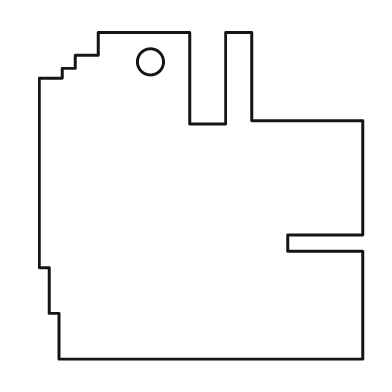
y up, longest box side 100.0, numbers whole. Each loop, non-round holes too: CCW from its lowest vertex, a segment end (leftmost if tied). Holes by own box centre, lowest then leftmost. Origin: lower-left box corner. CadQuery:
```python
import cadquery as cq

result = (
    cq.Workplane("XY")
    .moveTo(6.0, 0.0)
    .lineTo(99.0, 0.0)
    .lineTo(99.0, 33.0)
    .lineTo(76.0, 33.0)
    .lineTo(76.0, 38.0)
    .lineTo(99.0, 38.0)
    .lineTo(99.0, 73.0)
    .lineTo(65.0, 73.0)
    .lineTo(65.0, 100.0)
    .lineTo(57.0, 100.0)
    .lineTo(57.0, 72.0)
    .lineTo(46.0, 72.0)
    .lineTo(46.0, 100.0)
    .lineTo(18.0, 100.0)
    .lineTo(18.0, 93.0)
    .lineTo(11.0, 93.0)
    .lineTo(11.0, 89.0)
    .lineTo(7.0, 89.0)
    .lineTo(7.0, 86.0)
    .lineTo(0.0, 86.0)
    .lineTo(0.0, 28.0)
    .lineTo(3.0, 28.0)
    .lineTo(3.0, 14.0)
    .lineTo(6.0, 14.0)
    .close()
    .moveTo(34.0, 91.0)
    .circle(4.0)
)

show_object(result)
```